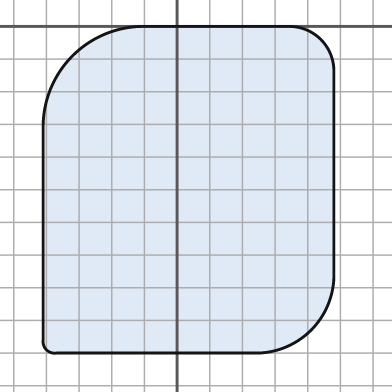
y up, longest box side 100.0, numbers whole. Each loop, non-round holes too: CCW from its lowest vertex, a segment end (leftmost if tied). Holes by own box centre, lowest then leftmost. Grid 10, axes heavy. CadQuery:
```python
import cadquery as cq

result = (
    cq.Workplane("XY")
    .moveTo(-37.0, -100.0)
    .lineTo(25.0, -100.0)
    .threePointArc((41.0, -93.0), (48.0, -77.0))
    .lineTo(48.0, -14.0)
    .threePointArc((44.0, -4.0), (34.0, 0.0))
    .lineTo(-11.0, 0.0)
    .threePointArc((-32.0, -9.0), (-41.0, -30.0))
    .lineTo(-41.0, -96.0)
    .threePointArc((-40.0, -99.0), (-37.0, -100.0))
    .close()
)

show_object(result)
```